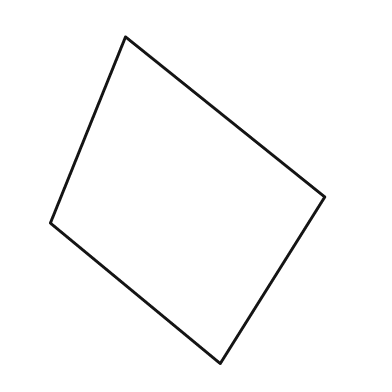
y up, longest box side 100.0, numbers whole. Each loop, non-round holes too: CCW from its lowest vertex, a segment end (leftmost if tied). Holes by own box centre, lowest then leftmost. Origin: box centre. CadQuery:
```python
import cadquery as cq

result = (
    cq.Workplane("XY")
    .moveTo(10.0, -50.0)
    .lineTo(42.0, 1.0)
    .lineTo(-19.0, 50.0)
    .lineTo(-42.0, -7.0)
    .close()
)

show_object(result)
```